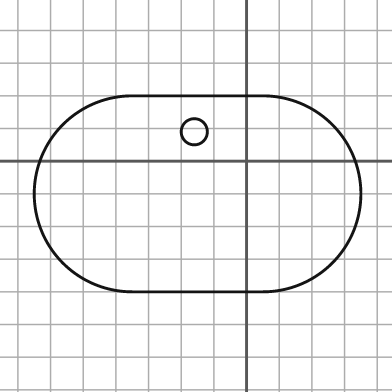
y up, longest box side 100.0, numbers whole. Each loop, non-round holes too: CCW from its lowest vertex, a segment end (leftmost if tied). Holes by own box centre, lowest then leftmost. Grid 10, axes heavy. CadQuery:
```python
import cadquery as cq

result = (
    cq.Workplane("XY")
    .moveTo(-35.0, -40.0)
    .lineTo(5.0, -40.0)
    .threePointArc((35.0, -10.0), (5.0, 20.0))
    .lineTo(-35.0, 20.0)
    .threePointArc((-65.0, -10.0), (-35.0, -40.0))
    .close()
    .moveTo(-16.0, 9.0)
    .circle(4.0)
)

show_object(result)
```